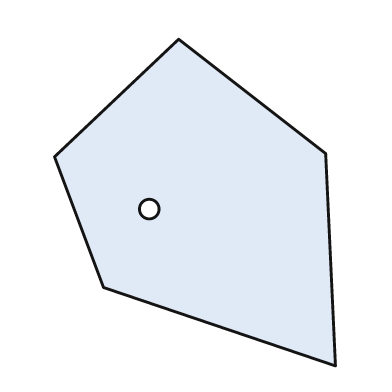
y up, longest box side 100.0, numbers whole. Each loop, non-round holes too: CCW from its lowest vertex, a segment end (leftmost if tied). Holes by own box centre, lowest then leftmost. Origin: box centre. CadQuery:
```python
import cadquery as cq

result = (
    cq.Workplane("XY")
    .moveTo(43.0, -50.0)
    .lineTo(40.0, 15.0)
    .lineTo(-5.0, 50.0)
    .lineTo(-43.0, 14.0)
    .lineTo(-28.0, -26.0)
    .close()
    .moveTo(-14.0, -2.0)
    .circle(3.0)
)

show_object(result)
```